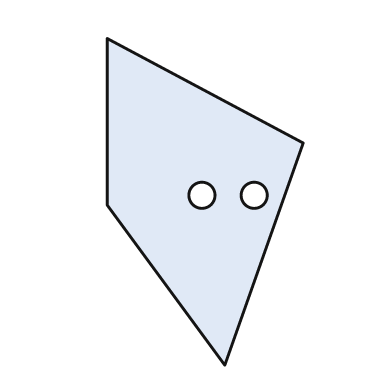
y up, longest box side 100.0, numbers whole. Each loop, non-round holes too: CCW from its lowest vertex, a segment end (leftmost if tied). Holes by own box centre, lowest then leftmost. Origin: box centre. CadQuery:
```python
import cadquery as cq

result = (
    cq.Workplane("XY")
    .moveTo(6.0, -50.0)
    .lineTo(30.0, 18.0)
    .lineTo(-30.0, 50.0)
    .lineTo(-30.0, -1.0)
    .close()
    .moveTo(-1.0, 2.0)
    .circle(4.0)
    .moveTo(15.0, 2.0)
    .circle(4.0)
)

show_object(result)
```